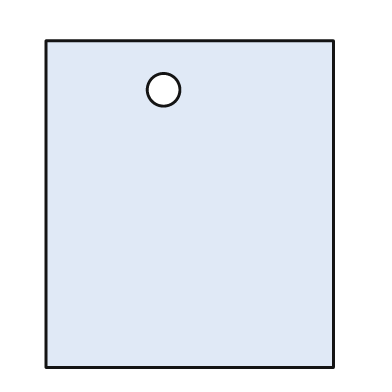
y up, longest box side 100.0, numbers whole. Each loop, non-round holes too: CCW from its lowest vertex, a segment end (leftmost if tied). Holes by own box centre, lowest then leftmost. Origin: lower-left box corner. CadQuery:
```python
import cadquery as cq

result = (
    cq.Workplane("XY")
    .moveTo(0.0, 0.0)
    .lineTo(88.0, 0.0)
    .lineTo(88.0, 100.0)
    .lineTo(0.0, 100.0)
    .close()
    .moveTo(36.0, 85.0)
    .circle(5.0)
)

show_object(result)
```